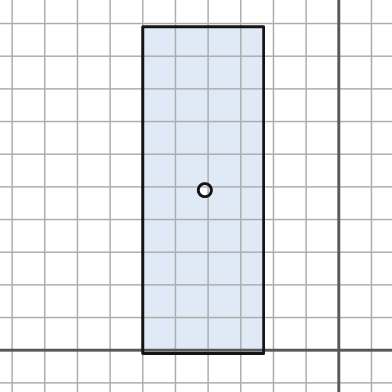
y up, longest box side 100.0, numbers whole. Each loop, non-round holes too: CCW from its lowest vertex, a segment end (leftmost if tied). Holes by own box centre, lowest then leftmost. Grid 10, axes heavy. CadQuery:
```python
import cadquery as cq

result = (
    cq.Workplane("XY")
    .moveTo(-60.0, -1.0)
    .lineTo(-23.0, -1.0)
    .lineTo(-23.0, 99.0)
    .lineTo(-60.0, 99.0)
    .close()
    .moveTo(-41.0, 49.0)
    .circle(2.0)
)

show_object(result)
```